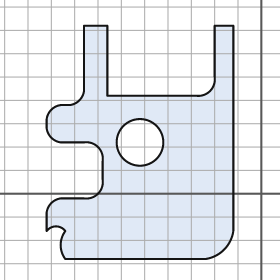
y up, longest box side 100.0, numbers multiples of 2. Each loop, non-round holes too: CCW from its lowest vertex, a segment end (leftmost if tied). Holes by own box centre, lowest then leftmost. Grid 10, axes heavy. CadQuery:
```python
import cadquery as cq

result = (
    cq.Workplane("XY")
    .moveTo(-84.0, -28.0)
    .lineTo(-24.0, -28.0)
    .threePointArc((-16.0, -24.0), (-12.0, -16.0))
    .lineTo(-12.0, 72.0)
    .lineTo(-20.0, 72.0)
    .lineTo(-20.0, 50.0)
    .threePointArc((-22.0, 44.0), (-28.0, 42.0))
    .lineTo(-66.0, 42.0)
    .lineTo(-66.0, 72.0)
    .lineTo(-76.0, 72.0)
    .lineTo(-76.0, 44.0)
    .threePointArc((-78.0, 40.0), (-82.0, 38.0))
    .lineTo(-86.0, 38.0)
    .threePointArc((-90.0, 36.0), (-92.0, 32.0))
    .lineTo(-92.0, 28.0)
    .threePointArc((-90.0, 24.0), (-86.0, 22.0))
    .lineTo(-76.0, 22.0)
    .threePointArc((-70.0, 20.0), (-68.0, 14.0))
    .lineTo(-68.0, 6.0)
    .threePointArc((-70.0, 0.0), (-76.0, -2.0))
    .lineTo(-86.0, -2.0)
    .threePointArc((-90.0, -4.0), (-92.0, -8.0))
    .lineTo(-92.0, -16.0)
    .threePointArc((-88.0, -14.0), (-84.0, -16.0))
    .threePointArc((-86.0, -22.0), (-84.0, -28.0))
    .close()
    .moveTo(-52.0, 22.0)
    .circle(10.0)
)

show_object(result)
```